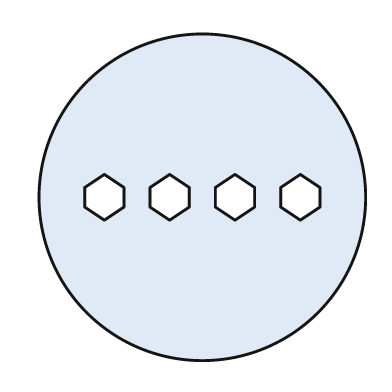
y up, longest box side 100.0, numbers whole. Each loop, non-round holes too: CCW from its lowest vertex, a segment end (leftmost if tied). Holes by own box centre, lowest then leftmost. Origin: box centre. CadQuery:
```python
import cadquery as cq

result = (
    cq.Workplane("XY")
    .moveTo(0.0, 0.0)
    .circle(50.0)
    .moveTo(-30.0, -7.0)
    .lineTo(-24.0, -3.0)
    .lineTo(-24.0, 3.0)
    .lineTo(-30.0, 7.0)
    .lineTo(-36.0, 3.0)
    .lineTo(-36.0, -3.0)
    .close()
    .moveTo(-10.0, -7.0)
    .lineTo(-4.0, -3.0)
    .lineTo(-4.0, 3.0)
    .lineTo(-10.0, 7.0)
    .lineTo(-16.0, 3.0)
    .lineTo(-16.0, -3.0)
    .close()
    .moveTo(10.0, -7.0)
    .lineTo(16.0, -3.0)
    .lineTo(16.0, 3.0)
    .lineTo(10.0, 7.0)
    .lineTo(4.0, 3.0)
    .lineTo(4.0, -3.0)
    .close()
    .moveTo(30.0, -7.0)
    .lineTo(36.0, -3.0)
    .lineTo(36.0, 3.0)
    .lineTo(30.0, 7.0)
    .lineTo(24.0, 3.0)
    .lineTo(24.0, -3.0)
    .close()
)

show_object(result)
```